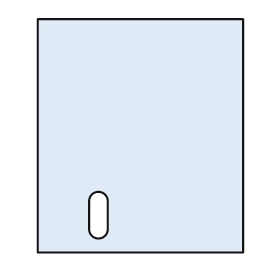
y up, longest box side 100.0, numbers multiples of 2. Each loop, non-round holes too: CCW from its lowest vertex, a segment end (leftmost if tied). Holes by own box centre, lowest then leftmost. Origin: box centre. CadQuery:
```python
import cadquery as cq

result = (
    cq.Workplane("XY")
    .moveTo(-44.0, -50.0)
    .lineTo(44.0, -50.0)
    .lineTo(44.0, 50.0)
    .lineTo(-44.0, 50.0)
    .close()
    .moveTo(-22.0, -40.0)
    .threePointArc((-18.0, -44.0), (-14.0, -40.0))
    .lineTo(-14.0, -28.0)
    .threePointArc((-18.0, -24.0), (-22.0, -28.0))
    .close()
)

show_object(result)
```